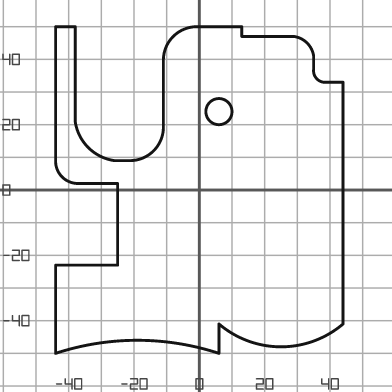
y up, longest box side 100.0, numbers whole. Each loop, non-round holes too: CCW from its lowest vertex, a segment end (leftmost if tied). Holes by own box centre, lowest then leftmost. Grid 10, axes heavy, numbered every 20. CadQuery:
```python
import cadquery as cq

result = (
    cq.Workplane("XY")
    .moveTo(-44.0, -50.0)
    .threePointArc((-19.0, -46.0), (6.0, -50.0))
    .lineTo(6.0, -41.0)
    .threePointArc((25.0, -48.0), (44.0, -41.0))
    .lineTo(44.0, 33.0)
    .lineTo(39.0, 33.0)
    .threePointArc((36.0, 34.0), (35.0, 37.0))
    .lineTo(35.0, 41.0)
    .threePointArc((33.0, 45.0), (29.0, 47.0))
    .lineTo(13.0, 47.0)
    .lineTo(13.0, 50.0)
    .lineTo(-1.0, 50.0)
    .threePointArc((-8.0, 47.0), (-11.0, 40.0))
    .lineTo(-11.0, 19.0)
    .threePointArc((-14.0, 12.0), (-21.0, 9.0))
    .lineTo(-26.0, 9.0)
    .threePointArc((-34.0, 13.0), (-38.0, 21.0))
    .lineTo(-38.0, 50.0)
    .lineTo(-44.0, 50.0)
    .lineTo(-44.0, 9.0)
    .threePointArc((-42.0, 4.0), (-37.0, 2.0))
    .lineTo(-25.0, 2.0)
    .lineTo(-25.0, -23.0)
    .lineTo(-44.0, -23.0)
    .close()
    .moveTo(6.0, 24.0)
    .circle(4.0)
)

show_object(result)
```